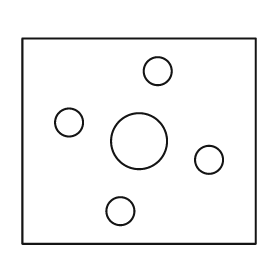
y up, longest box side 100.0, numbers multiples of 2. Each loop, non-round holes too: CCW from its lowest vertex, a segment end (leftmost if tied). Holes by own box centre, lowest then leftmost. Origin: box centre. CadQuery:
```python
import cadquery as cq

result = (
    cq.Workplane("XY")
    .moveTo(-50.0, -44.0)
    .lineTo(50.0, -44.0)
    .lineTo(50.0, 44.0)
    .lineTo(-50.0, 44.0)
    .close()
    .moveTo(-8.0, -30.0)
    .circle(6.0)
    .moveTo(30.0, -8.0)
    .circle(6.0)
    .moveTo(0.0, 0.0)
    .circle(12.0)
    .moveTo(-30.0, 8.0)
    .circle(6.0)
    .moveTo(8.0, 30.0)
    .circle(6.0)
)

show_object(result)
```